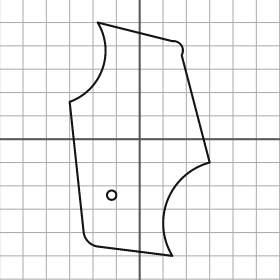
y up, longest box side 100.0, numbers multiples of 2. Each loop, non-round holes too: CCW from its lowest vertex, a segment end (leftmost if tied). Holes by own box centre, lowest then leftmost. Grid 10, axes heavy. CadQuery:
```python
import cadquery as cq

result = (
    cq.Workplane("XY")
    .moveTo(14.0, -50.0)
    .threePointArc((12.0, -26.0), (30.0, -10.0))
    .lineTo(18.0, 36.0)
    .threePointArc((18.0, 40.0), (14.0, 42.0))
    .lineTo(-18.0, 50.0)
    .threePointArc((-16.0, 30.0), (-30.0, 16.0))
    .lineTo(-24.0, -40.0)
    .threePointArc((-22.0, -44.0), (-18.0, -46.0))
    .close()
    .moveTo(-12.0, -24.0)
    .circle(2.0)
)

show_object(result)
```